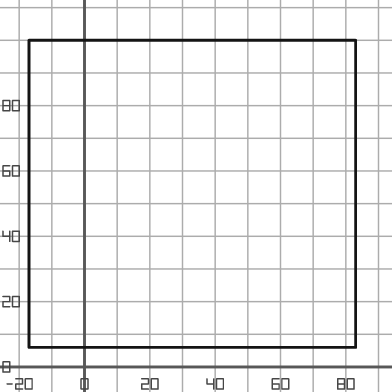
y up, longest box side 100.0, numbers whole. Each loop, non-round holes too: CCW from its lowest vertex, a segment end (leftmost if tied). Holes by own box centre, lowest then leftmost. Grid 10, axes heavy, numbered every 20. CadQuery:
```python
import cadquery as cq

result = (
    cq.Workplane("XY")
    .moveTo(-17.0, 6.0)
    .lineTo(83.0, 6.0)
    .lineTo(83.0, 100.0)
    .lineTo(-17.0, 100.0)
    .close()
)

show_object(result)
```